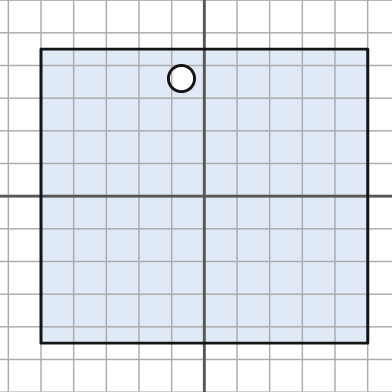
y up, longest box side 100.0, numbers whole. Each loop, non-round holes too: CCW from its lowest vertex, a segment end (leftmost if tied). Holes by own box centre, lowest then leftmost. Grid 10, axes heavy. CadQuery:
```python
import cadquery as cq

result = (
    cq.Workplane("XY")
    .moveTo(-50.0, -45.0)
    .lineTo(50.0, -45.0)
    .lineTo(50.0, 45.0)
    .lineTo(-50.0, 45.0)
    .close()
    .moveTo(-7.0, 36.0)
    .circle(4.0)
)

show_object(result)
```